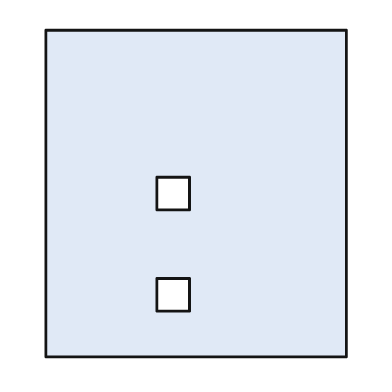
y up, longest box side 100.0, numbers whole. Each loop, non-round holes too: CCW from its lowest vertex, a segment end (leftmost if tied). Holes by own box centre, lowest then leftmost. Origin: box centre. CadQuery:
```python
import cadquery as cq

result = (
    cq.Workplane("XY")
    .moveTo(-46.0, -50.0)
    .lineTo(46.0, -50.0)
    .lineTo(46.0, 50.0)
    .lineTo(-46.0, 50.0)
    .close()
    .moveTo(-12.0, -36.0)
    .lineTo(-2.0, -36.0)
    .lineTo(-2.0, -26.0)
    .lineTo(-12.0, -26.0)
    .close()
    .moveTo(-12.0, -5.0)
    .lineTo(-2.0, -5.0)
    .lineTo(-2.0, 5.0)
    .lineTo(-12.0, 5.0)
    .close()
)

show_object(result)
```